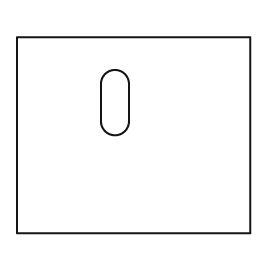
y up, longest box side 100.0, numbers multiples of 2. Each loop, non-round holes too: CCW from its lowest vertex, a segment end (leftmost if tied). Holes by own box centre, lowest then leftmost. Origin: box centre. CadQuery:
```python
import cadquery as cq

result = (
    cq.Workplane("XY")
    .moveTo(-50.0, -42.0)
    .lineTo(50.0, -42.0)
    .lineTo(50.0, 42.0)
    .lineTo(-50.0, 42.0)
    .close()
    .moveTo(-14.0, 6.0)
    .threePointArc((-8.0, 0.0), (-2.0, 6.0))
    .lineTo(-2.0, 22.0)
    .threePointArc((-8.0, 28.0), (-14.0, 22.0))
    .close()
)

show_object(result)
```